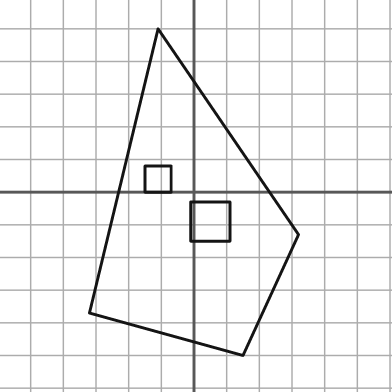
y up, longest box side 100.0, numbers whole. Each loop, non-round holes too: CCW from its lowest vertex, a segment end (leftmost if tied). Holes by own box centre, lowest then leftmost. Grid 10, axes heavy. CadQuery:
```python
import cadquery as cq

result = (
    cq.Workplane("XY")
    .moveTo(15.0, -50.0)
    .lineTo(32.0, -13.0)
    .lineTo(-11.0, 50.0)
    .lineTo(-32.0, -37.0)
    .close()
    .moveTo(-1.0, -15.0)
    .lineTo(11.0, -15.0)
    .lineTo(11.0, -3.0)
    .lineTo(-1.0, -3.0)
    .close()
    .moveTo(-15.0, 0.0)
    .lineTo(-7.0, 0.0)
    .lineTo(-7.0, 8.0)
    .lineTo(-15.0, 8.0)
    .close()
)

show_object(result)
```